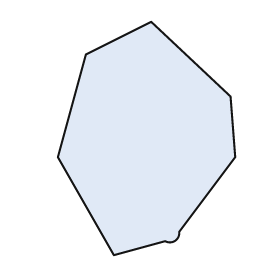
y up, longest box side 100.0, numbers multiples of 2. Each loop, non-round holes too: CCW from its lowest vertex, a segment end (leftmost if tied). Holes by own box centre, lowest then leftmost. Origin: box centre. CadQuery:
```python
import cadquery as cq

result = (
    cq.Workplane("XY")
    .moveTo(-14.0, -50.0)
    .lineTo(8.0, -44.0)
    .threePointArc((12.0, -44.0), (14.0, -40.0))
    .lineTo(38.0, -8.0)
    .lineTo(36.0, 18.0)
    .lineTo(2.0, 50.0)
    .lineTo(-26.0, 36.0)
    .lineTo(-38.0, -8.0)
    .close()
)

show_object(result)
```